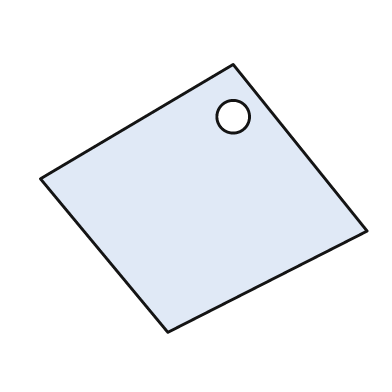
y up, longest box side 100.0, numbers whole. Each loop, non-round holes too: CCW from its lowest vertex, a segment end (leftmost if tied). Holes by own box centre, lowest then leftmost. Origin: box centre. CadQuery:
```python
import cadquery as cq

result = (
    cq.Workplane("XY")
    .moveTo(-11.0, -41.0)
    .lineTo(50.0, -10.0)
    .lineTo(9.0, 41.0)
    .lineTo(-50.0, 6.0)
    .close()
    .moveTo(9.0, 25.0)
    .circle(5.0)
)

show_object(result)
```